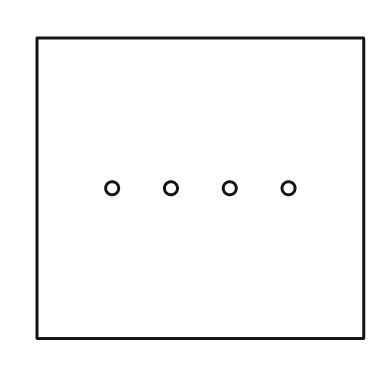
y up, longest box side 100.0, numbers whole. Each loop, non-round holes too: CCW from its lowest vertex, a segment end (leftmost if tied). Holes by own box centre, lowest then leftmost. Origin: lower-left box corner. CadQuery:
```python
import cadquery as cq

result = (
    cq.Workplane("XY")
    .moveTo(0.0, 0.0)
    .lineTo(100.0, 0.0)
    .lineTo(100.0, 92.0)
    .lineTo(0.0, 92.0)
    .close()
    .moveTo(23.0, 46.0)
    .circle(2.0)
    .moveTo(41.0, 46.0)
    .circle(2.0)
    .moveTo(59.0, 46.0)
    .circle(2.0)
    .moveTo(77.0, 46.0)
    .circle(2.0)
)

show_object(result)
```